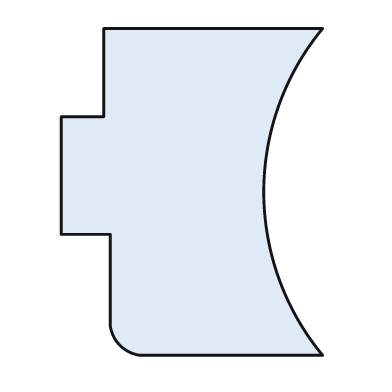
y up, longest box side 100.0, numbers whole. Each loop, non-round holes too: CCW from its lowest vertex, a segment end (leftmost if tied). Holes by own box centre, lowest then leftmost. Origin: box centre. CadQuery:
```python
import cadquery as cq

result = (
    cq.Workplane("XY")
    .moveTo(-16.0, -50.0)
    .lineTo(40.0, -50.0)
    .threePointArc((22.0, 0.0), (40.0, 50.0))
    .lineTo(-27.0, 50.0)
    .lineTo(-27.0, 23.0)
    .lineTo(-40.0, 23.0)
    .lineTo(-40.0, -13.0)
    .lineTo(-25.0, -13.0)
    .lineTo(-25.0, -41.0)
    .threePointArc((-22.0, -47.0), (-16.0, -50.0))
    .close()
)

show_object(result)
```